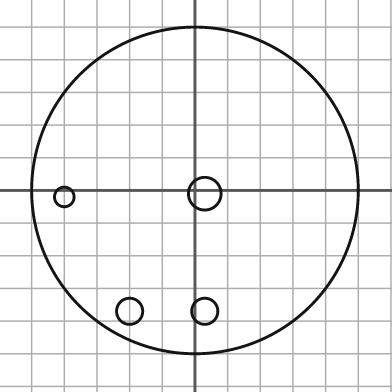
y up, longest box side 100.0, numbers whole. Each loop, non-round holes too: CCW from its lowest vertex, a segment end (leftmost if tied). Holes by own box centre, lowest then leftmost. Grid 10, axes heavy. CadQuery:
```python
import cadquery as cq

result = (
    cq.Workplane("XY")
    .moveTo(0.0, 0.0)
    .circle(50.0)
    .moveTo(-20.0, -37.0)
    .circle(4.0)
    .moveTo(3.0, -37.0)
    .circle(4.0)
    .moveTo(-40.0, -2.0)
    .circle(3.0)
    .moveTo(3.0, -1.0)
    .circle(5.0)
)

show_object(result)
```